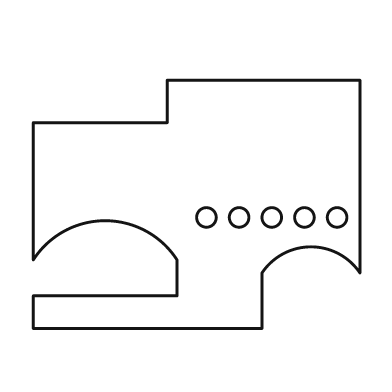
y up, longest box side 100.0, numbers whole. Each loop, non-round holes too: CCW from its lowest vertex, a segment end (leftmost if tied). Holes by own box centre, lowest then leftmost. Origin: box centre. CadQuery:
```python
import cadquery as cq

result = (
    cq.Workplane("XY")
    .moveTo(-50.0, -38.0)
    .lineTo(20.0, -38.0)
    .lineTo(20.0, -21.0)
    .threePointArc((35.0, -13.0), (50.0, -21.0))
    .lineTo(50.0, 38.0)
    .lineTo(-9.0, 38.0)
    .lineTo(-9.0, 25.0)
    .lineTo(-50.0, 25.0)
    .lineTo(-50.0, -17.0)
    .threePointArc((-28.0, -5.0), (-6.0, -17.0))
    .lineTo(-6.0, -28.0)
    .lineTo(-50.0, -28.0)
    .close()
    .moveTo(3.0, -4.0)
    .circle(3.0)
    .moveTo(13.0, -4.0)
    .circle(3.0)
    .moveTo(23.0, -4.0)
    .circle(3.0)
    .moveTo(33.0, -4.0)
    .circle(3.0)
    .moveTo(43.0, -4.0)
    .circle(3.0)
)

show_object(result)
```